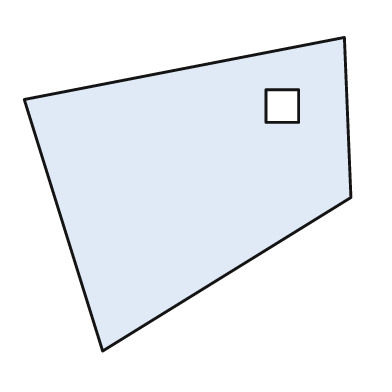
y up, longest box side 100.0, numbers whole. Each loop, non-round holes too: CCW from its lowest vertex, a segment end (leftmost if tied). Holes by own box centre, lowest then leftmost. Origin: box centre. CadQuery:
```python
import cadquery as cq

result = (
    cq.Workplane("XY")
    .moveTo(-26.0, -48.0)
    .lineTo(50.0, -1.0)
    .lineTo(48.0, 48.0)
    .lineTo(-50.0, 29.0)
    .close()
    .moveTo(24.0, 22.0)
    .lineTo(34.0, 22.0)
    .lineTo(34.0, 32.0)
    .lineTo(24.0, 32.0)
    .close()
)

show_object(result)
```